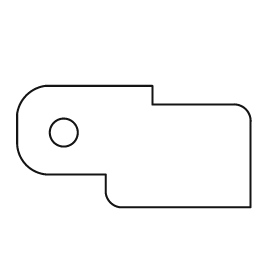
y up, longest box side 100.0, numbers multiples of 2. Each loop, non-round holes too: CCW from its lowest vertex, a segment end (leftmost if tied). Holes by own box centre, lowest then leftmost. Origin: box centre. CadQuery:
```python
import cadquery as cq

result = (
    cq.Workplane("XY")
    .moveTo(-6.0, -26.0)
    .lineTo(50.0, -26.0)
    .lineTo(50.0, 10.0)
    .threePointArc((48.0, 16.0), (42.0, 18.0))
    .lineTo(8.0, 18.0)
    .lineTo(8.0, 26.0)
    .lineTo(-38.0, 26.0)
    .threePointArc((-46.0, 22.0), (-50.0, 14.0))
    .lineTo(-50.0, 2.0)
    .threePointArc((-46.0, -8.0), (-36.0, -12.0))
    .lineTo(-12.0, -12.0)
    .lineTo(-12.0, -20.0)
    .threePointArc((-10.0, -24.0), (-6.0, -26.0))
    .close()
    .moveTo(-30.0, 6.0)
    .circle(6.0)
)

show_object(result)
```